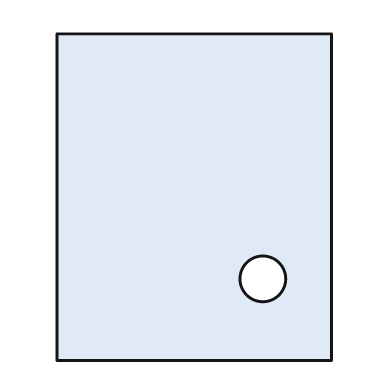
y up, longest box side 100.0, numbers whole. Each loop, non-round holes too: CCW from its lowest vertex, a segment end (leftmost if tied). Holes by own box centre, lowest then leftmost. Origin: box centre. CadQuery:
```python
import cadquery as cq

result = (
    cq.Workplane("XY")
    .moveTo(-42.0, -50.0)
    .lineTo(42.0, -50.0)
    .lineTo(42.0, 50.0)
    .lineTo(-42.0, 50.0)
    .close()
    .moveTo(21.0, -25.0)
    .circle(7.0)
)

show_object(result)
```